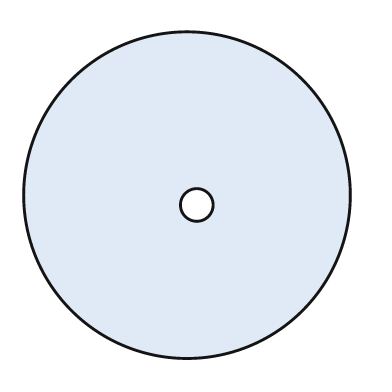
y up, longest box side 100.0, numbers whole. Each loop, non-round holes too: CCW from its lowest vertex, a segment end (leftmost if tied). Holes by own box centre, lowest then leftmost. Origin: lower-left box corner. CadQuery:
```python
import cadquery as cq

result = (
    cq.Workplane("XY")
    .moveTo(50.0, 50.0)
    .circle(50.0)
    .moveTo(53.0, 47.0)
    .circle(5.0)
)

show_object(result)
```